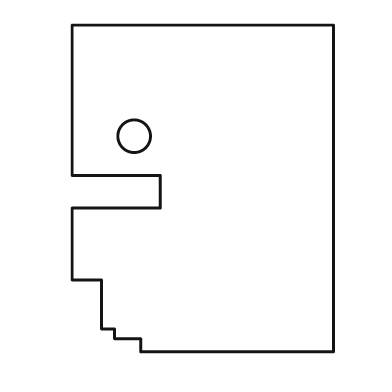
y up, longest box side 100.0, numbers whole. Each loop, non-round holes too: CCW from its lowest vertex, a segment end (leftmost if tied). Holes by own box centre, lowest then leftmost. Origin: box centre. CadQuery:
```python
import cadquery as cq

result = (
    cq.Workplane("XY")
    .moveTo(-19.0, -50.0)
    .lineTo(40.0, -50.0)
    .lineTo(40.0, 50.0)
    .lineTo(-40.0, 50.0)
    .lineTo(-40.0, 4.0)
    .lineTo(-13.0, 4.0)
    .lineTo(-13.0, -6.0)
    .lineTo(-40.0, -6.0)
    .lineTo(-40.0, -28.0)
    .lineTo(-31.0, -28.0)
    .lineTo(-31.0, -43.0)
    .lineTo(-27.0, -43.0)
    .lineTo(-27.0, -46.0)
    .lineTo(-19.0, -46.0)
    .close()
    .moveTo(-21.0, 16.0)
    .circle(5.0)
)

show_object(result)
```